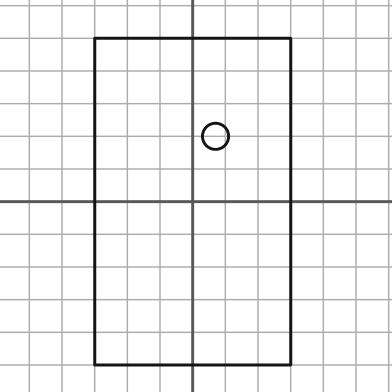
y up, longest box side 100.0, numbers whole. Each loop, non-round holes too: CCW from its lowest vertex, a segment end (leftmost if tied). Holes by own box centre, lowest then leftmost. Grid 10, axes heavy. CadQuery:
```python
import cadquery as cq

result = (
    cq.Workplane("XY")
    .moveTo(-30.0, -50.0)
    .lineTo(30.0, -50.0)
    .lineTo(30.0, 50.0)
    .lineTo(-30.0, 50.0)
    .close()
    .moveTo(7.0, 20.0)
    .circle(4.0)
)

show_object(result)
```